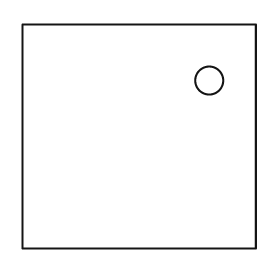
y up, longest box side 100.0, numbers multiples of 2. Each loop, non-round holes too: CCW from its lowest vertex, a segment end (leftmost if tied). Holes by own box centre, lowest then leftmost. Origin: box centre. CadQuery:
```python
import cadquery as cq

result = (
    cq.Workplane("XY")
    .moveTo(-50.0, -48.0)
    .lineTo(50.0, -48.0)
    .lineTo(50.0, 48.0)
    .lineTo(-50.0, 48.0)
    .close()
    .moveTo(30.0, 24.0)
    .circle(6.0)
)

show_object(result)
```